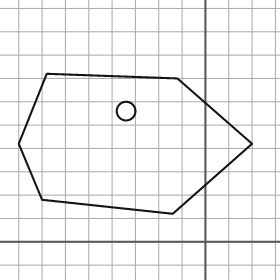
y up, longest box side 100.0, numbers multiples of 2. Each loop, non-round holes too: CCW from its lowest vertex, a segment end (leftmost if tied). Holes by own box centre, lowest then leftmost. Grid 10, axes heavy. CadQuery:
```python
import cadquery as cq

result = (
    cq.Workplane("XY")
    .moveTo(-14.0, 12.0)
    .lineTo(20.0, 42.0)
    .lineTo(-12.0, 70.0)
    .lineTo(-68.0, 72.0)
    .lineTo(-80.0, 42.0)
    .lineTo(-70.0, 18.0)
    .close()
    .moveTo(-34.0, 56.0)
    .circle(4.0)
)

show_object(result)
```